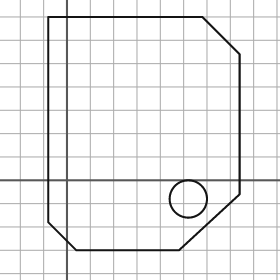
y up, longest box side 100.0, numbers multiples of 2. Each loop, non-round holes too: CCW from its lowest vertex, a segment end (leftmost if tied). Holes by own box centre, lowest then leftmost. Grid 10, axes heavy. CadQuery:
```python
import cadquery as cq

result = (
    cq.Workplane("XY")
    .moveTo(4.0, -30.0)
    .lineTo(48.0, -30.0)
    .lineTo(74.0, -6.0)
    .lineTo(74.0, 54.0)
    .lineTo(58.0, 70.0)
    .lineTo(-8.0, 70.0)
    .lineTo(-8.0, -18.0)
    .close()
    .moveTo(52.0, -8.0)
    .circle(8.0)
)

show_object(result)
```